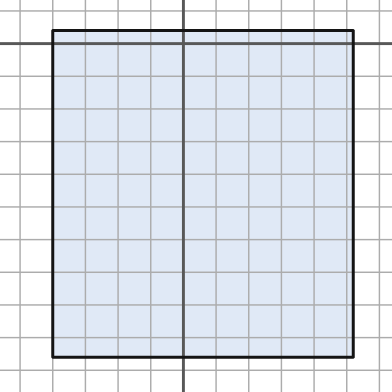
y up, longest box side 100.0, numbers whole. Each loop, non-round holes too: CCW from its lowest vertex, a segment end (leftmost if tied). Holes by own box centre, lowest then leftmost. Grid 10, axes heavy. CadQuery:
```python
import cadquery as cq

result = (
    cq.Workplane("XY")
    .moveTo(-40.0, -96.0)
    .lineTo(52.0, -96.0)
    .lineTo(52.0, 4.0)
    .lineTo(-40.0, 4.0)
    .close()
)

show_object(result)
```